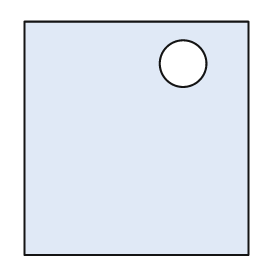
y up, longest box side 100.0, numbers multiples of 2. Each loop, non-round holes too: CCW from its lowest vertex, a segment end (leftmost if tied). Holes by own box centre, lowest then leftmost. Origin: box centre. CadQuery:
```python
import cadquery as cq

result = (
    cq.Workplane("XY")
    .moveTo(-48.0, -50.0)
    .lineTo(48.0, -50.0)
    .lineTo(48.0, 50.0)
    .lineTo(-48.0, 50.0)
    .close()
    .moveTo(20.0, 32.0)
    .circle(10.0)
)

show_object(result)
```